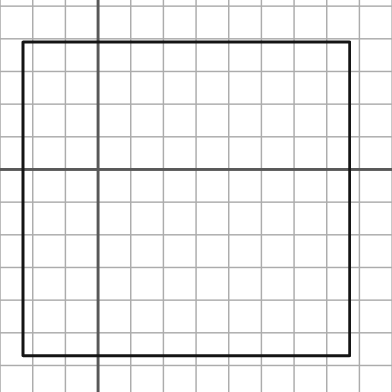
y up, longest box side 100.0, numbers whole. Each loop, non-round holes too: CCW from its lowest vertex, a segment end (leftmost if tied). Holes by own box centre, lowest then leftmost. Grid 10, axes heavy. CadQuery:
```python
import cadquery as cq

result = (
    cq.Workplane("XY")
    .moveTo(-23.0, -57.0)
    .lineTo(77.0, -57.0)
    .lineTo(77.0, 39.0)
    .lineTo(-23.0, 39.0)
    .close()
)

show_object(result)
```